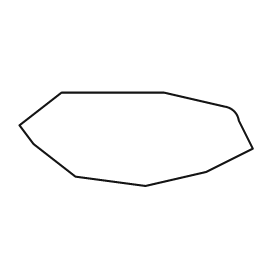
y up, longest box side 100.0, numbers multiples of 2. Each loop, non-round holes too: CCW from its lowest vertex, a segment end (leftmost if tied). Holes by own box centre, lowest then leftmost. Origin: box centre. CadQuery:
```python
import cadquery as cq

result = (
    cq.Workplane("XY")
    .moveTo(4.0, -20.0)
    .lineTo(30.0, -14.0)
    .lineTo(50.0, -4.0)
    .lineTo(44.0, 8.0)
    .threePointArc((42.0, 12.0), (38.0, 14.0))
    .lineTo(12.0, 20.0)
    .lineTo(-32.0, 20.0)
    .lineTo(-50.0, 6.0)
    .lineTo(-44.0, -2.0)
    .lineTo(-26.0, -16.0)
    .close()
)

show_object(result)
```